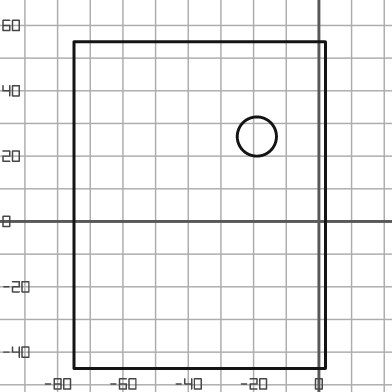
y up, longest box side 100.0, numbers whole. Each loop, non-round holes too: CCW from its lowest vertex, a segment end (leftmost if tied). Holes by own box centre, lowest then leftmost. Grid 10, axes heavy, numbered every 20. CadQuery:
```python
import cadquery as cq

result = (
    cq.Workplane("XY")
    .moveTo(-75.0, -45.0)
    .lineTo(2.0, -45.0)
    .lineTo(2.0, 55.0)
    .lineTo(-75.0, 55.0)
    .close()
    .moveTo(-19.0, 26.0)
    .circle(6.0)
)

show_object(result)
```